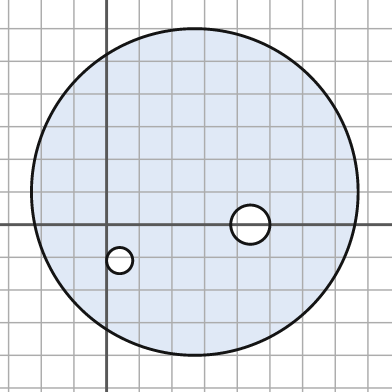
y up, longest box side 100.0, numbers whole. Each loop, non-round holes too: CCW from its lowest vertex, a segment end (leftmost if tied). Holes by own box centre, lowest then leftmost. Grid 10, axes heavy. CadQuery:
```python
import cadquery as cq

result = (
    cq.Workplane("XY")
    .moveTo(27.0, 10.0)
    .circle(50.0)
    .moveTo(4.0, -11.0)
    .circle(4.0)
    .moveTo(44.0, 0.0)
    .circle(6.0)
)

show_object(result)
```